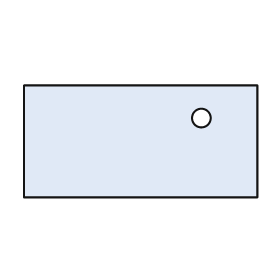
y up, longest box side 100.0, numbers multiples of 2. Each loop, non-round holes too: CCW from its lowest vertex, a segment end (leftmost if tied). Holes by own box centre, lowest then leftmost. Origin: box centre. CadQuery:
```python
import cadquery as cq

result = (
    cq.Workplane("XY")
    .moveTo(-50.0, -24.0)
    .lineTo(50.0, -24.0)
    .lineTo(50.0, 24.0)
    .lineTo(-50.0, 24.0)
    .close()
    .moveTo(26.0, 10.0)
    .circle(4.0)
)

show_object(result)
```